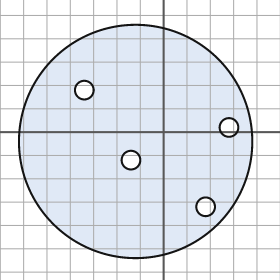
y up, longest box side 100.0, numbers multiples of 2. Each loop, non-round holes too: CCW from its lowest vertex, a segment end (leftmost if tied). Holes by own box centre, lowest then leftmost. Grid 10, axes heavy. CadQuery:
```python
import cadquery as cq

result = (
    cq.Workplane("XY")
    .moveTo(-12.0, -4.0)
    .circle(50.0)
    .moveTo(18.0, -32.0)
    .circle(4.0)
    .moveTo(-14.0, -12.0)
    .circle(4.0)
    .moveTo(28.0, 2.0)
    .circle(4.0)
    .moveTo(-34.0, 18.0)
    .circle(4.0)
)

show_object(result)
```